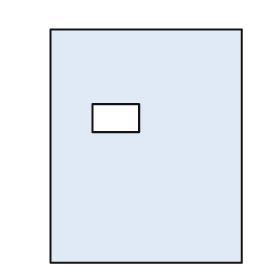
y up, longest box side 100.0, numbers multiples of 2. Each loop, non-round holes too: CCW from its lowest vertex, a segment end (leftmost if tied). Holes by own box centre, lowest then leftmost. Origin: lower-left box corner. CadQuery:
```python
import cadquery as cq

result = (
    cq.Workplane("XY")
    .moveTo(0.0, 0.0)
    .lineTo(82.0, 0.0)
    .lineTo(82.0, 100.0)
    .lineTo(0.0, 100.0)
    .close()
    .moveTo(18.0, 56.0)
    .lineTo(38.0, 56.0)
    .lineTo(38.0, 68.0)
    .lineTo(18.0, 68.0)
    .close()
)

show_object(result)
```